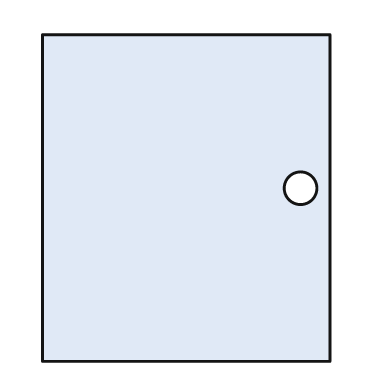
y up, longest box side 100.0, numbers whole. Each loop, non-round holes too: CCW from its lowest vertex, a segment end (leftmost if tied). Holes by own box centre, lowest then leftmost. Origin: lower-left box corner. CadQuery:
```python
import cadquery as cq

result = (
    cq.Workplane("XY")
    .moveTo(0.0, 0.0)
    .lineTo(88.0, 0.0)
    .lineTo(88.0, 100.0)
    .lineTo(0.0, 100.0)
    .close()
    .moveTo(79.0, 53.0)
    .circle(5.0)
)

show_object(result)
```